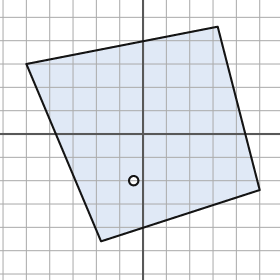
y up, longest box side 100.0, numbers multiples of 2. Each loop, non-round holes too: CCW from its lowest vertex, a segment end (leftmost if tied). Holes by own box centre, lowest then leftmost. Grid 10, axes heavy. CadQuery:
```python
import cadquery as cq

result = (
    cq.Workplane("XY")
    .moveTo(-18.0, -46.0)
    .lineTo(50.0, -24.0)
    .lineTo(32.0, 46.0)
    .lineTo(-50.0, 30.0)
    .close()
    .moveTo(-4.0, -20.0)
    .circle(2.0)
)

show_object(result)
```